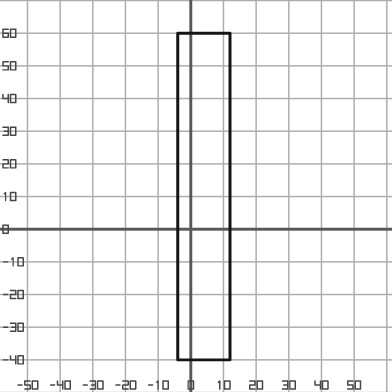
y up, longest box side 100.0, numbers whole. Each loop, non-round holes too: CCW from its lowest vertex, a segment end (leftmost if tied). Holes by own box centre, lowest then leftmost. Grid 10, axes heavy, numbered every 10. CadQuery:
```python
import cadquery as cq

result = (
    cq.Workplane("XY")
    .moveTo(-4.0, -40.0)
    .lineTo(12.0, -40.0)
    .lineTo(12.0, 60.0)
    .lineTo(-4.0, 60.0)
    .close()
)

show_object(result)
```